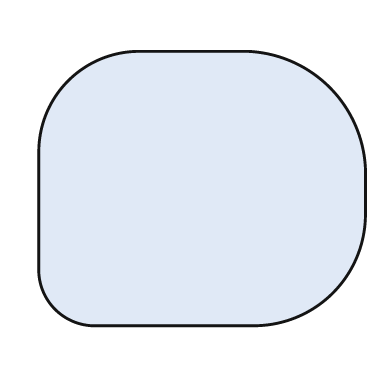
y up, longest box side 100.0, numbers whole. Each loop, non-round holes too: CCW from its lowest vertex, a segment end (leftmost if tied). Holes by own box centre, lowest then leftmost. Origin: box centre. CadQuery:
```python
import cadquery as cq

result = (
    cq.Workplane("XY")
    .moveTo(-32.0, -42.0)
    .lineTo(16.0, -42.0)
    .threePointArc((40.0, -32.0), (50.0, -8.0))
    .lineTo(50.0, 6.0)
    .threePointArc((39.0, 31.0), (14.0, 42.0))
    .lineTo(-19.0, 42.0)
    .threePointArc((-41.0, 33.0), (-50.0, 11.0))
    .lineTo(-50.0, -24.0)
    .threePointArc((-45.0, -37.0), (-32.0, -42.0))
    .close()
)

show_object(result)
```